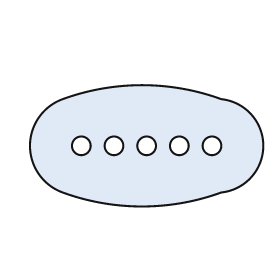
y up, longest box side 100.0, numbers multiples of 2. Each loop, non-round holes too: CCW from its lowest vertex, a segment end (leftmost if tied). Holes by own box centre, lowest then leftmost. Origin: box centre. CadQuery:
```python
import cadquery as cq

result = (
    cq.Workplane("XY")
    .moveTo(-36.0, -20.0)
    .threePointArc((-2.0, -26.0), (32.0, -20.0))
    .threePointArc((50.0, 0.0), (32.0, 20.0))
    .threePointArc((-2.0, 26.0), (-36.0, 20.0))
    .threePointArc((-50.0, 0.0), (-36.0, -20.0))
    .close()
    .moveTo(-28.0, 0.0)
    .circle(4.0)
    .moveTo(-14.0, 0.0)
    .circle(4.0)
    .moveTo(0.0, 0.0)
    .circle(4.0)
    .moveTo(14.0, 0.0)
    .circle(4.0)
    .moveTo(28.0, 0.0)
    .circle(4.0)
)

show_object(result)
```